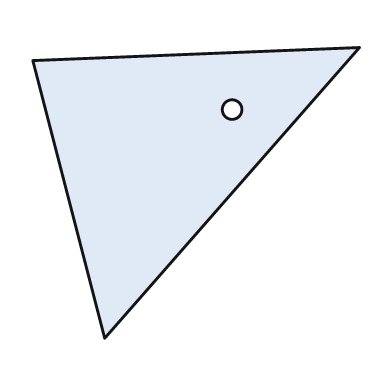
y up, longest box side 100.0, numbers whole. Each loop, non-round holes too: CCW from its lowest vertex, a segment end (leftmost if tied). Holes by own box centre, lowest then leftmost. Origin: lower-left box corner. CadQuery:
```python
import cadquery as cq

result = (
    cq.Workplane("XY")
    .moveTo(22.0, 0.0)
    .lineTo(100.0, 89.0)
    .lineTo(0.0, 85.0)
    .close()
    .moveTo(61.0, 70.0)
    .circle(3.0)
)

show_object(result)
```